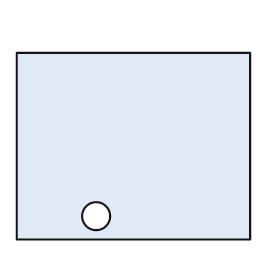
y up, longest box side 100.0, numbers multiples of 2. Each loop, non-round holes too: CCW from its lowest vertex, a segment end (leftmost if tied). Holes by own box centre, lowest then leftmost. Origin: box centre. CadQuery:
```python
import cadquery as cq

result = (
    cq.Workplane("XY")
    .moveTo(-50.0, -40.0)
    .lineTo(50.0, -40.0)
    .lineTo(50.0, 40.0)
    .lineTo(-50.0, 40.0)
    .close()
    .moveTo(-16.0, -30.0)
    .circle(6.0)
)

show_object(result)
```